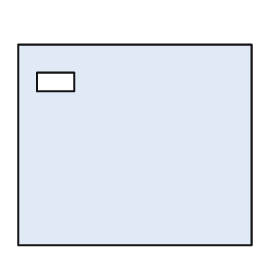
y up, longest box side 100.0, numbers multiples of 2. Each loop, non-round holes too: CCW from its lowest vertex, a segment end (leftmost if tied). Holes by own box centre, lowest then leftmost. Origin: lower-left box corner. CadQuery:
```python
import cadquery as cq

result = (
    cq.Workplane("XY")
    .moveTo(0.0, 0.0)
    .lineTo(100.0, 0.0)
    .lineTo(100.0, 86.0)
    .lineTo(0.0, 86.0)
    .close()
    .moveTo(8.0, 66.0)
    .lineTo(24.0, 66.0)
    .lineTo(24.0, 74.0)
    .lineTo(8.0, 74.0)
    .close()
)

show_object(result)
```